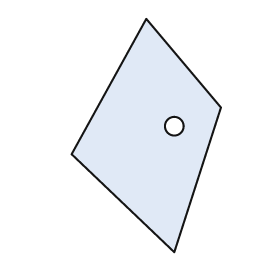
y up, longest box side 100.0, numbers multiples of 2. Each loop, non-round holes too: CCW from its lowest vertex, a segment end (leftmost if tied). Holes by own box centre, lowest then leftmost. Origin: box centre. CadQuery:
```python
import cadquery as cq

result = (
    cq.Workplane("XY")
    .moveTo(12.0, -50.0)
    .lineTo(32.0, 12.0)
    .lineTo(0.0, 50.0)
    .lineTo(-32.0, -8.0)
    .close()
    .moveTo(12.0, 4.0)
    .circle(4.0)
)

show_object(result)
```